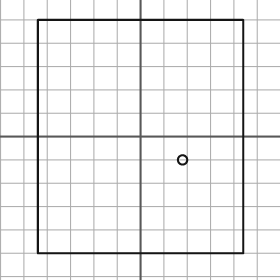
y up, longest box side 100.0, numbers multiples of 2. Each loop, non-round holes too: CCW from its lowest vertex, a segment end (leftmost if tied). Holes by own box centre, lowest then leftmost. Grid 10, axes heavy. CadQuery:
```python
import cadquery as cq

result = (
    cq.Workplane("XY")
    .moveTo(-44.0, -50.0)
    .lineTo(44.0, -50.0)
    .lineTo(44.0, 50.0)
    .lineTo(-44.0, 50.0)
    .close()
    .moveTo(18.0, -10.0)
    .circle(2.0)
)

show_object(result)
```